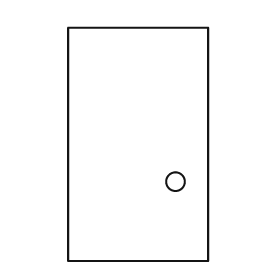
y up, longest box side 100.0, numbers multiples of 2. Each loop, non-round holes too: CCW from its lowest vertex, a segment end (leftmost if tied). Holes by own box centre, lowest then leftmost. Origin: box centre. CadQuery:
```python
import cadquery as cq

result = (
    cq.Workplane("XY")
    .moveTo(-30.0, -50.0)
    .lineTo(30.0, -50.0)
    .lineTo(30.0, 50.0)
    .lineTo(-30.0, 50.0)
    .close()
    .moveTo(16.0, -16.0)
    .circle(4.0)
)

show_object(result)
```